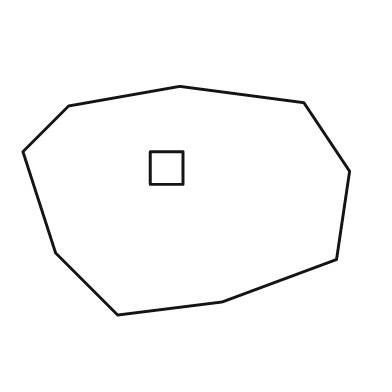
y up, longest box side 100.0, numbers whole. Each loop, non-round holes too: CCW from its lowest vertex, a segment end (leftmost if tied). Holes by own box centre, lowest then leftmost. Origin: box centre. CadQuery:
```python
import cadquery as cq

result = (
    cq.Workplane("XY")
    .moveTo(-21.0, -35.0)
    .lineTo(11.0, -31.0)
    .lineTo(46.0, -18.0)
    .lineTo(50.0, 9.0)
    .lineTo(36.0, 30.0)
    .lineTo(-2.0, 35.0)
    .lineTo(-36.0, 29.0)
    .lineTo(-50.0, 15.0)
    .lineTo(-40.0, -16.0)
    .close()
    .moveTo(-11.0, 5.0)
    .lineTo(-1.0, 5.0)
    .lineTo(-1.0, 15.0)
    .lineTo(-11.0, 15.0)
    .close()
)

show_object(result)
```